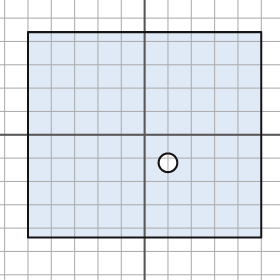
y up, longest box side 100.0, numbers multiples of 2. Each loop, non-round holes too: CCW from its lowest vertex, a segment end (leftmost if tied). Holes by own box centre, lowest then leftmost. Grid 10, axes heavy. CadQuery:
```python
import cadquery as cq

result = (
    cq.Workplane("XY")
    .moveTo(-50.0, -44.0)
    .lineTo(50.0, -44.0)
    .lineTo(50.0, 44.0)
    .lineTo(-50.0, 44.0)
    .close()
    .moveTo(10.0, -12.0)
    .circle(4.0)
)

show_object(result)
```